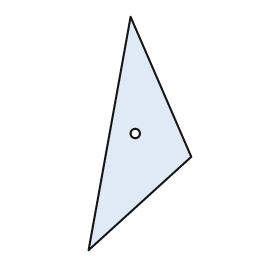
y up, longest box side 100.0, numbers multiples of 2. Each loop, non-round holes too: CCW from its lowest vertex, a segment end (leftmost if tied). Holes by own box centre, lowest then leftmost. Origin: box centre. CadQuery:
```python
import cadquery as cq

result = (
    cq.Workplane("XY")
    .moveTo(-22.0, -50.0)
    .lineTo(22.0, -10.0)
    .lineTo(-4.0, 50.0)
    .close()
    .moveTo(-2.0, 0.0)
    .circle(2.0)
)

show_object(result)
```